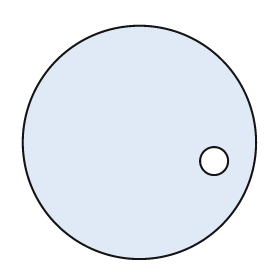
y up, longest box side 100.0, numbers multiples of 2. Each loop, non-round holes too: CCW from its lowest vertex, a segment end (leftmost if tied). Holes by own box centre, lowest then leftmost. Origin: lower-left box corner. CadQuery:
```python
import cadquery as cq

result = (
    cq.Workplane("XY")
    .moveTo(50.0, 50.0)
    .circle(50.0)
    .moveTo(82.0, 42.0)
    .circle(6.0)
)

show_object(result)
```